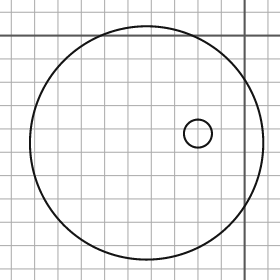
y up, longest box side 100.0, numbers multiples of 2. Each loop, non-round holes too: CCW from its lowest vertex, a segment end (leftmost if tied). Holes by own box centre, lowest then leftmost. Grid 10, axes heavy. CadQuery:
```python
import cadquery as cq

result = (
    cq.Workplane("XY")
    .moveTo(-42.0, -46.0)
    .circle(50.0)
    .moveTo(-20.0, -42.0)
    .circle(6.0)
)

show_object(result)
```